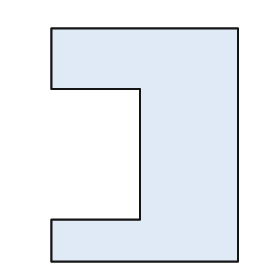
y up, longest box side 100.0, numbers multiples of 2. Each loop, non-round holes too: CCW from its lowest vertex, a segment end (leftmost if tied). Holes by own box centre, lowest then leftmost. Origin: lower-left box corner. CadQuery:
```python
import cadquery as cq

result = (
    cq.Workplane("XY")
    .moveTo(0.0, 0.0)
    .lineTo(80.0, 0.0)
    .lineTo(80.0, 100.0)
    .lineTo(0.0, 100.0)
    .lineTo(0.0, 74.0)
    .lineTo(38.0, 74.0)
    .lineTo(38.0, 18.0)
    .lineTo(0.0, 18.0)
    .close()
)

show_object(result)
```